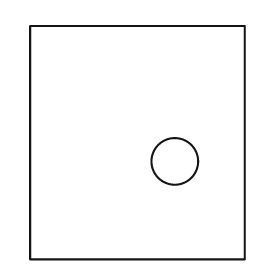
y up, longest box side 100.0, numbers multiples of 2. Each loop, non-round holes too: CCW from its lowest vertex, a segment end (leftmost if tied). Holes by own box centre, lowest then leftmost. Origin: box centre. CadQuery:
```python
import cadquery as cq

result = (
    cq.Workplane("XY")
    .moveTo(-46.0, -50.0)
    .lineTo(46.0, -50.0)
    .lineTo(46.0, 50.0)
    .lineTo(-46.0, 50.0)
    .close()
    .moveTo(16.0, -8.0)
    .circle(10.0)
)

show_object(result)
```